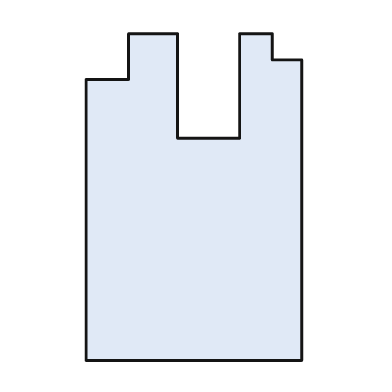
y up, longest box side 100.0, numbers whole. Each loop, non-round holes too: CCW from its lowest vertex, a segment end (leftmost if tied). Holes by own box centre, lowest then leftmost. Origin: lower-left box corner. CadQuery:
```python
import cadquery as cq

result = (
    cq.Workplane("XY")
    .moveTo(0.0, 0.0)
    .lineTo(66.0, 0.0)
    .lineTo(66.0, 92.0)
    .lineTo(57.0, 92.0)
    .lineTo(57.0, 100.0)
    .lineTo(47.0, 100.0)
    .lineTo(47.0, 68.0)
    .lineTo(28.0, 68.0)
    .lineTo(28.0, 100.0)
    .lineTo(13.0, 100.0)
    .lineTo(13.0, 86.0)
    .lineTo(0.0, 86.0)
    .close()
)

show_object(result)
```